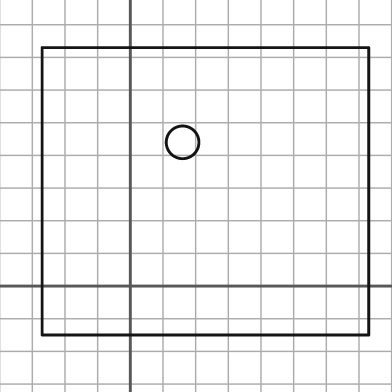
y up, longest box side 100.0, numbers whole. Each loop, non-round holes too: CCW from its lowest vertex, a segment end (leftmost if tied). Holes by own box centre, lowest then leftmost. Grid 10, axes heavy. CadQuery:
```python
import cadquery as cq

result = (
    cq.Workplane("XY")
    .moveTo(-27.0, -15.0)
    .lineTo(73.0, -15.0)
    .lineTo(73.0, 73.0)
    .lineTo(-27.0, 73.0)
    .close()
    .moveTo(16.0, 44.0)
    .circle(5.0)
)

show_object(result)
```